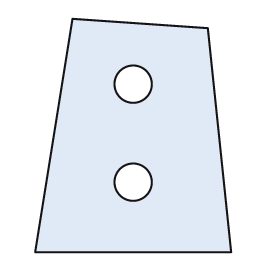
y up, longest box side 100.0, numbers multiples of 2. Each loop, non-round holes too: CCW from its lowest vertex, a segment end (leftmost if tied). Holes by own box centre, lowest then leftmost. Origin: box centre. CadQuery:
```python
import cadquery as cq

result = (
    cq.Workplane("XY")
    .moveTo(-42.0, -50.0)
    .lineTo(42.0, -50.0)
    .lineTo(32.0, 46.0)
    .lineTo(-26.0, 50.0)
    .close()
    .moveTo(0.0, -20.0)
    .circle(8.0)
    .moveTo(0.0, 22.0)
    .circle(8.0)
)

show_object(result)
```